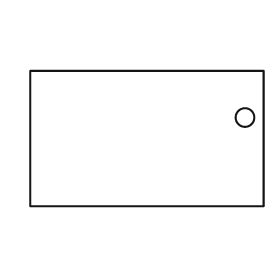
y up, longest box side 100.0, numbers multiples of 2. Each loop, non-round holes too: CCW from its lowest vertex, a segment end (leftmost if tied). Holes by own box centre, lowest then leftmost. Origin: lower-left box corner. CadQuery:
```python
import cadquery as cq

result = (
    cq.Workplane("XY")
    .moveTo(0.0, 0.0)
    .lineTo(100.0, 0.0)
    .lineTo(100.0, 58.0)
    .lineTo(0.0, 58.0)
    .close()
    .moveTo(92.0, 38.0)
    .circle(4.0)
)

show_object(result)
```